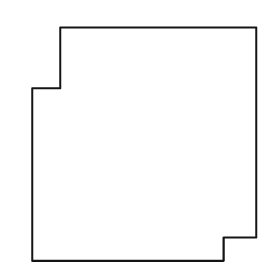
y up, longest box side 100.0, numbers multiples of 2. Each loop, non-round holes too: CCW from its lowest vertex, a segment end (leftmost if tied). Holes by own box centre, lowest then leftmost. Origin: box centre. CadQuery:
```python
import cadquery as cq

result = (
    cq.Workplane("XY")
    .moveTo(-48.0, -50.0)
    .lineTo(34.0, -50.0)
    .lineTo(34.0, -40.0)
    .lineTo(48.0, -40.0)
    .lineTo(48.0, 50.0)
    .lineTo(-36.0, 50.0)
    .lineTo(-36.0, 24.0)
    .lineTo(-48.0, 24.0)
    .close()
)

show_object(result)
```